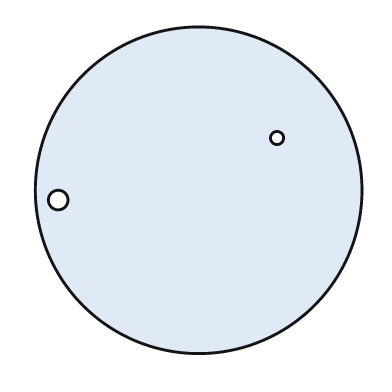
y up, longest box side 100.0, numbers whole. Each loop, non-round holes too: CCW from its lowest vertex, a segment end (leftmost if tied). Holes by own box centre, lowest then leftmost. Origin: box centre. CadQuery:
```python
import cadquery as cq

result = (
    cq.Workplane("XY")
    .moveTo(0.0, 0.0)
    .circle(50.0)
    .moveTo(-43.0, -3.0)
    .circle(3.0)
    .moveTo(24.0, 16.0)
    .circle(2.0)
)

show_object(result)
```